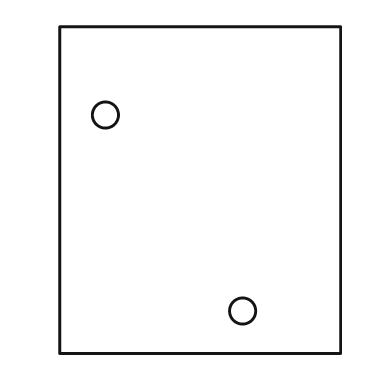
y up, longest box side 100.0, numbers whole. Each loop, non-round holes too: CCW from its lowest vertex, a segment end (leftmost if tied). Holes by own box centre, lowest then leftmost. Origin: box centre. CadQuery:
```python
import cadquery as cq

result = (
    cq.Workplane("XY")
    .moveTo(-43.0, -50.0)
    .lineTo(43.0, -50.0)
    .lineTo(43.0, 50.0)
    .lineTo(-43.0, 50.0)
    .close()
    .moveTo(13.0, -37.0)
    .circle(4.0)
    .moveTo(-29.0, 23.0)
    .circle(4.0)
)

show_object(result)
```